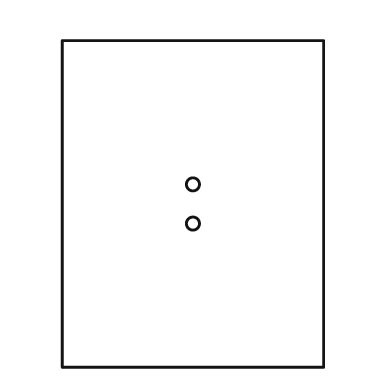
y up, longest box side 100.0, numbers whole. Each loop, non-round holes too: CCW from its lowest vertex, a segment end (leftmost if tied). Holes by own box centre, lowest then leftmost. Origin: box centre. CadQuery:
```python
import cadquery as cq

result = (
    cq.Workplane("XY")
    .moveTo(-40.0, -50.0)
    .lineTo(40.0, -50.0)
    .lineTo(40.0, 50.0)
    .lineTo(-40.0, 50.0)
    .close()
    .moveTo(0.0, -6.0)
    .circle(2.0)
    .moveTo(0.0, 6.0)
    .circle(2.0)
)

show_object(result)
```